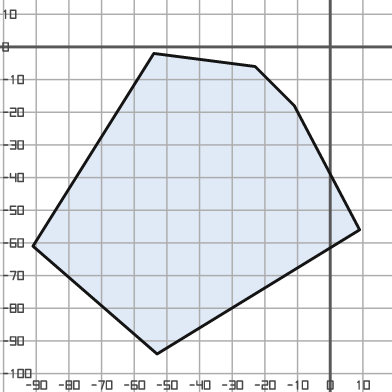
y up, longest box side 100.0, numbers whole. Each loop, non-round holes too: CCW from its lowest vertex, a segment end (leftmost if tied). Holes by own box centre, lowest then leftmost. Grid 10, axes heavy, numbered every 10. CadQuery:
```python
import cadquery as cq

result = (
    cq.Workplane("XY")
    .moveTo(-53.0, -94.0)
    .lineTo(9.0, -56.0)
    .lineTo(-11.0, -18.0)
    .lineTo(-23.0, -6.0)
    .lineTo(-54.0, -2.0)
    .lineTo(-91.0, -61.0)
    .close()
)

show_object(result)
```